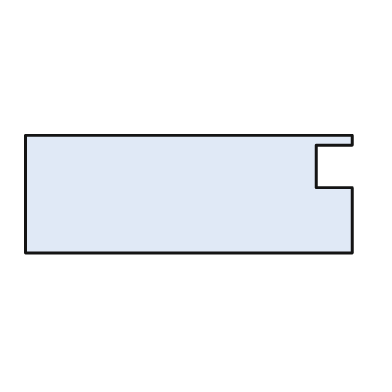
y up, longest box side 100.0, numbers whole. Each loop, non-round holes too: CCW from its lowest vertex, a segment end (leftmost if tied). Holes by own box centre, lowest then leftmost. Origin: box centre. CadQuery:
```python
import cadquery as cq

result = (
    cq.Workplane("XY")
    .moveTo(-50.0, -18.0)
    .lineTo(50.0, -18.0)
    .lineTo(50.0, 2.0)
    .lineTo(39.0, 2.0)
    .lineTo(39.0, 15.0)
    .lineTo(50.0, 15.0)
    .lineTo(50.0, 18.0)
    .lineTo(-50.0, 18.0)
    .close()
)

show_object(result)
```